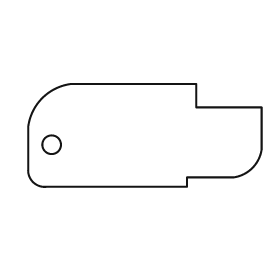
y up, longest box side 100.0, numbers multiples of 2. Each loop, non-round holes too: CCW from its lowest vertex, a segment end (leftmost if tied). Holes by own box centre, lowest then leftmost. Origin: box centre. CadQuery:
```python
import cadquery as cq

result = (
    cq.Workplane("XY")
    .moveTo(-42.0, -22.0)
    .lineTo(18.0, -22.0)
    .lineTo(18.0, -18.0)
    .lineTo(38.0, -18.0)
    .threePointArc((46.0, -14.0), (50.0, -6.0))
    .lineTo(50.0, 12.0)
    .lineTo(22.0, 12.0)
    .lineTo(22.0, 22.0)
    .lineTo(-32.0, 22.0)
    .threePointArc((-44.0, 16.0), (-50.0, 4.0))
    .lineTo(-50.0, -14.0)
    .threePointArc((-48.0, -20.0), (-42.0, -22.0))
    .close()
    .moveTo(-40.0, -4.0)
    .circle(4.0)
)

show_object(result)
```